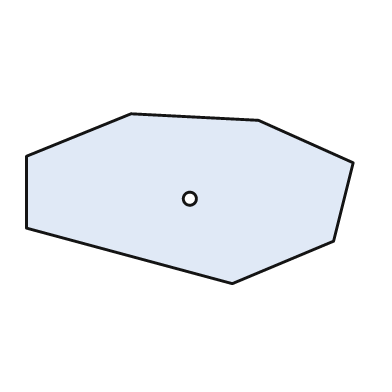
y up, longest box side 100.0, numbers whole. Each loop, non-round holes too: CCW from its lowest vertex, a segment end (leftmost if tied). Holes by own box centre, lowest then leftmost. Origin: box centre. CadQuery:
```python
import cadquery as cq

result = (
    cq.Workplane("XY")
    .moveTo(13.0, -26.0)
    .lineTo(44.0, -13.0)
    .lineTo(50.0, 11.0)
    .lineTo(21.0, 24.0)
    .lineTo(-18.0, 26.0)
    .lineTo(-50.0, 13.0)
    .lineTo(-50.0, -9.0)
    .close()
    .moveTo(0.0, 0.0)
    .circle(2.0)
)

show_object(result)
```